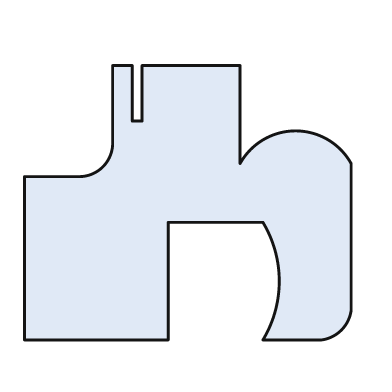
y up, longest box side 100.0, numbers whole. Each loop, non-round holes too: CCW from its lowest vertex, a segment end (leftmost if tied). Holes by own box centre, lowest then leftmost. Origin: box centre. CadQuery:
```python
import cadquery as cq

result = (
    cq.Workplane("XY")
    .moveTo(-50.0, -42.0)
    .lineTo(-6.0, -42.0)
    .lineTo(-6.0, -6.0)
    .lineTo(23.0, -6.0)
    .threePointArc((28.0, -24.0), (23.0, -42.0))
    .lineTo(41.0, -42.0)
    .threePointArc((47.0, -39.0), (50.0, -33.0))
    .lineTo(50.0, 12.0)
    .threePointArc((33.0, 22.0), (16.0, 12.0))
    .lineTo(16.0, 42.0)
    .lineTo(-14.0, 42.0)
    .lineTo(-14.0, 25.0)
    .lineTo(-17.0, 25.0)
    .lineTo(-17.0, 42.0)
    .lineTo(-23.0, 42.0)
    .lineTo(-23.0, 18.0)
    .threePointArc((-26.0, 11.0), (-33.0, 8.0))
    .lineTo(-50.0, 8.0)
    .close()
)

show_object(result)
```